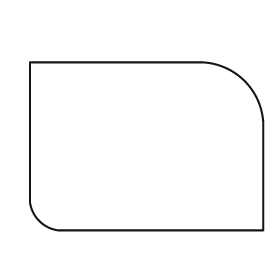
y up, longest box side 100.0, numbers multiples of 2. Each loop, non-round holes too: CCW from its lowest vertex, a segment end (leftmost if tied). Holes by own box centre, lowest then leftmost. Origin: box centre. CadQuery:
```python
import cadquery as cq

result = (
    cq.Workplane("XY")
    .moveTo(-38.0, -36.0)
    .lineTo(50.0, -36.0)
    .lineTo(50.0, 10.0)
    .threePointArc((42.0, 28.0), (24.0, 36.0))
    .lineTo(-50.0, 36.0)
    .lineTo(-50.0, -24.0)
    .threePointArc((-46.0, -32.0), (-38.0, -36.0))
    .close()
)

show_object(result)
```